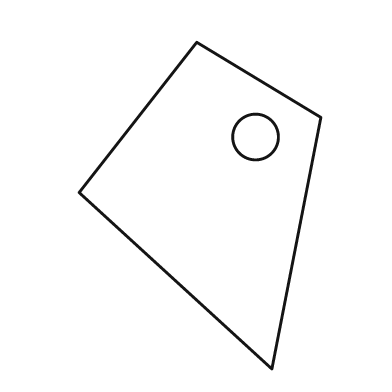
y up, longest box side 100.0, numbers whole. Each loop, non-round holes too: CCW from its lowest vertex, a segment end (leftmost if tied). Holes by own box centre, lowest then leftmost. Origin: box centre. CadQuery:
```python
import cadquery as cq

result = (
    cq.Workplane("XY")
    .moveTo(22.0, -50.0)
    .lineTo(37.0, 27.0)
    .lineTo(-1.0, 50.0)
    .lineTo(-37.0, 4.0)
    .close()
    .moveTo(17.0, 21.0)
    .circle(7.0)
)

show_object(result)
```